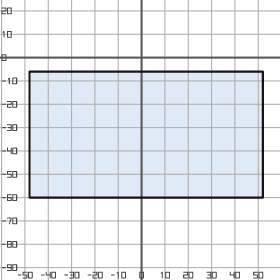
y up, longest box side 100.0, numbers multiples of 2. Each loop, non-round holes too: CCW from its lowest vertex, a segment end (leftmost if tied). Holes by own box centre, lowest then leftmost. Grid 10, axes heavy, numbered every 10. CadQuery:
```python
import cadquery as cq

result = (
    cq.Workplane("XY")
    .moveTo(-48.0, -60.0)
    .lineTo(52.0, -60.0)
    .lineTo(52.0, -6.0)
    .lineTo(-48.0, -6.0)
    .close()
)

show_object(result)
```